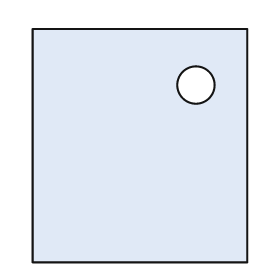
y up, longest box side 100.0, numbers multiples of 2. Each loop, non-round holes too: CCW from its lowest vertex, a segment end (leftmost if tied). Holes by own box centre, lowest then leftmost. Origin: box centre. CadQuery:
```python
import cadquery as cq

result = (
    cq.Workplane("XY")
    .moveTo(-46.0, -50.0)
    .lineTo(46.0, -50.0)
    .lineTo(46.0, 50.0)
    .lineTo(-46.0, 50.0)
    .close()
    .moveTo(24.0, 26.0)
    .circle(8.0)
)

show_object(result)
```